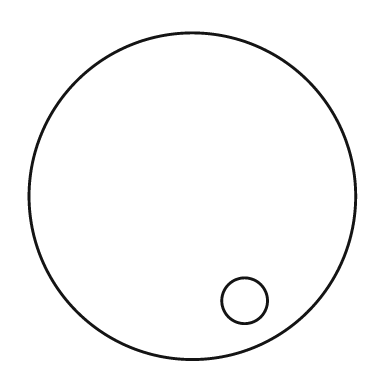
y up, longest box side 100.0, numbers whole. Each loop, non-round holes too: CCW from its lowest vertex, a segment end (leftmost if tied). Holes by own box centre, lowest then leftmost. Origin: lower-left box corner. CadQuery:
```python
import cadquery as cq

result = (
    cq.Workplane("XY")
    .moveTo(50.0, 50.0)
    .circle(50.0)
    .moveTo(66.0, 18.0)
    .circle(7.0)
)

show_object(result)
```